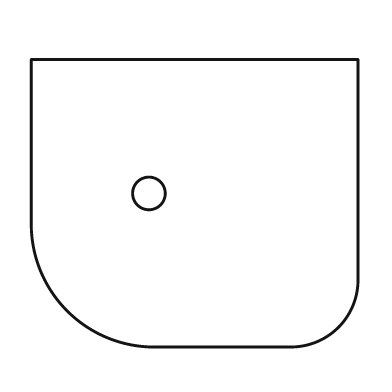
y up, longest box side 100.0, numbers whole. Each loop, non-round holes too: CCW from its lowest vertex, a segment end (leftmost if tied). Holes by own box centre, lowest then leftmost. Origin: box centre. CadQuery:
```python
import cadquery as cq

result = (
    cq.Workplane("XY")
    .moveTo(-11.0, -44.0)
    .lineTo(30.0, -44.0)
    .threePointArc((44.0, -38.0), (50.0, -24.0))
    .lineTo(50.0, 44.0)
    .lineTo(-50.0, 44.0)
    .lineTo(-50.0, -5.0)
    .threePointArc((-39.0, -33.0), (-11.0, -44.0))
    .close()
    .moveTo(-14.0, 3.0)
    .circle(5.0)
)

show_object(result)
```